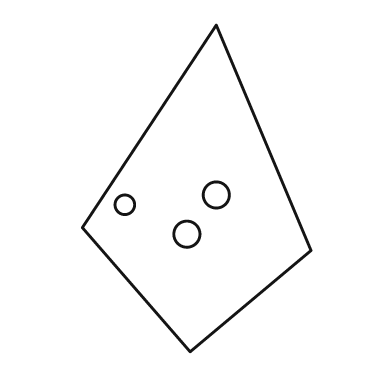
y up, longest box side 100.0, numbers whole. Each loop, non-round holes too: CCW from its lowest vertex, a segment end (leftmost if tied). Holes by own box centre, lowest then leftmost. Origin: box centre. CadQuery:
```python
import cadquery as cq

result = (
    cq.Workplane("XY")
    .moveTo(-2.0, -50.0)
    .lineTo(35.0, -19.0)
    .lineTo(6.0, 50.0)
    .lineTo(-35.0, -12.0)
    .close()
    .moveTo(-3.0, -14.0)
    .circle(4.0)
    .moveTo(-22.0, -5.0)
    .circle(3.0)
    .moveTo(6.0, -2.0)
    .circle(4.0)
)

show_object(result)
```